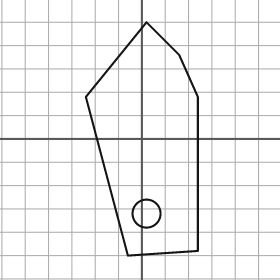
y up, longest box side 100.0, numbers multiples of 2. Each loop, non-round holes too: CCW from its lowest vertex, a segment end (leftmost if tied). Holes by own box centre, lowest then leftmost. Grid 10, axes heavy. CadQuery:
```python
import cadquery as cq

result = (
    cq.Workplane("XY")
    .moveTo(-6.0, -50.0)
    .lineTo(24.0, -48.0)
    .lineTo(24.0, 18.0)
    .lineTo(16.0, 36.0)
    .lineTo(2.0, 50.0)
    .lineTo(-24.0, 18.0)
    .close()
    .moveTo(2.0, -32.0)
    .circle(6.0)
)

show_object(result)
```